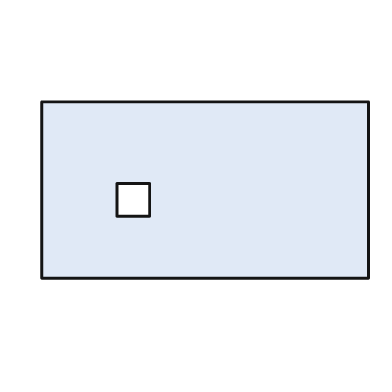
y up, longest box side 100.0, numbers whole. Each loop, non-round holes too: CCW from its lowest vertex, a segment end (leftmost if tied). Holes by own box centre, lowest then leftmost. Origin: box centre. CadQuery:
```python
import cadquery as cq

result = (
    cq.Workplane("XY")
    .moveTo(-50.0, -27.0)
    .lineTo(50.0, -27.0)
    .lineTo(50.0, 27.0)
    .lineTo(-50.0, 27.0)
    .close()
    .moveTo(-27.0, -8.0)
    .lineTo(-17.0, -8.0)
    .lineTo(-17.0, 2.0)
    .lineTo(-27.0, 2.0)
    .close()
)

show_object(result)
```